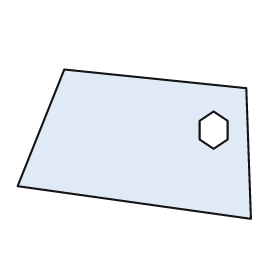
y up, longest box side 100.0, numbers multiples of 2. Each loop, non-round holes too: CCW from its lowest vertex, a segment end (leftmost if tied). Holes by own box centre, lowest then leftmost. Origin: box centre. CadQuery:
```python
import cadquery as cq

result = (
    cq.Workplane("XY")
    .moveTo(50.0, -32.0)
    .lineTo(48.0, 24.0)
    .lineTo(-30.0, 32.0)
    .lineTo(-50.0, -18.0)
    .close()
    .moveTo(34.0, -2.0)
    .lineTo(40.0, 2.0)
    .lineTo(40.0, 10.0)
    .lineTo(34.0, 14.0)
    .lineTo(28.0, 10.0)
    .lineTo(28.0, 2.0)
    .close()
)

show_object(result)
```